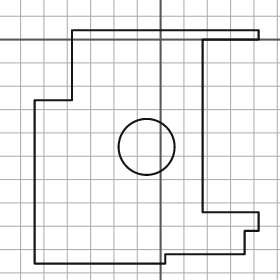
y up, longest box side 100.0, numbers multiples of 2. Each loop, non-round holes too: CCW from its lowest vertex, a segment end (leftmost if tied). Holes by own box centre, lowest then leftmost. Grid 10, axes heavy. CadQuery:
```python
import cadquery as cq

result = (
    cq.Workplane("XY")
    .moveTo(-54.0, -96.0)
    .lineTo(2.0, -96.0)
    .lineTo(2.0, -92.0)
    .lineTo(36.0, -92.0)
    .lineTo(36.0, -82.0)
    .lineTo(42.0, -82.0)
    .lineTo(42.0, -74.0)
    .lineTo(18.0, -74.0)
    .lineTo(18.0, 0.0)
    .lineTo(42.0, 0.0)
    .lineTo(42.0, 4.0)
    .lineTo(-38.0, 4.0)
    .lineTo(-38.0, -26.0)
    .lineTo(-54.0, -26.0)
    .close()
    .moveTo(-6.0, -46.0)
    .circle(12.0)
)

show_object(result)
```